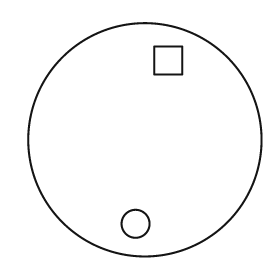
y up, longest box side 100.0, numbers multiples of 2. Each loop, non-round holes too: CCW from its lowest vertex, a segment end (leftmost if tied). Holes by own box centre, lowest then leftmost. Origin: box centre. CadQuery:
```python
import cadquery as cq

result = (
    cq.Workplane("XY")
    .moveTo(0.0, 0.0)
    .circle(50.0)
    .moveTo(-4.0, -36.0)
    .circle(6.0)
    .moveTo(4.0, 28.0)
    .lineTo(16.0, 28.0)
    .lineTo(16.0, 40.0)
    .lineTo(4.0, 40.0)
    .close()
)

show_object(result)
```